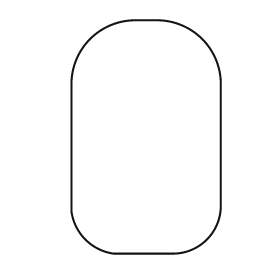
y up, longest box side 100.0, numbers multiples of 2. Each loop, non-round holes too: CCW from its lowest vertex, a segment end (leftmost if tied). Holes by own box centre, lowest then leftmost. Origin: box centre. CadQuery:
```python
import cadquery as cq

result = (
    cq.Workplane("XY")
    .moveTo(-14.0, -50.0)
    .lineTo(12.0, -50.0)
    .threePointArc((26.0, -44.0), (32.0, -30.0))
    .lineTo(32.0, 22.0)
    .threePointArc((24.0, 42.0), (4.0, 50.0))
    .lineTo(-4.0, 50.0)
    .threePointArc((-24.0, 42.0), (-32.0, 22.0))
    .lineTo(-32.0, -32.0)
    .threePointArc((-26.0, -44.0), (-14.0, -50.0))
    .close()
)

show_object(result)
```